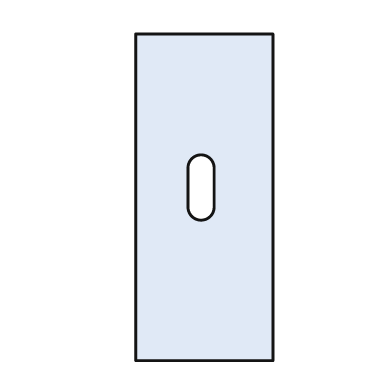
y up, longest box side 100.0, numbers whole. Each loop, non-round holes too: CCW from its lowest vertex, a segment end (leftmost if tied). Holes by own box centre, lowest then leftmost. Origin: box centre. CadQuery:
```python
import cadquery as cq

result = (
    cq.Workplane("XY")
    .moveTo(-21.0, -50.0)
    .lineTo(21.0, -50.0)
    .lineTo(21.0, 50.0)
    .lineTo(-21.0, 50.0)
    .close()
    .moveTo(-5.0, -3.0)
    .threePointArc((-1.0, -7.0), (3.0, -3.0))
    .lineTo(3.0, 9.0)
    .threePointArc((-1.0, 13.0), (-5.0, 9.0))
    .close()
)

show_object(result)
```